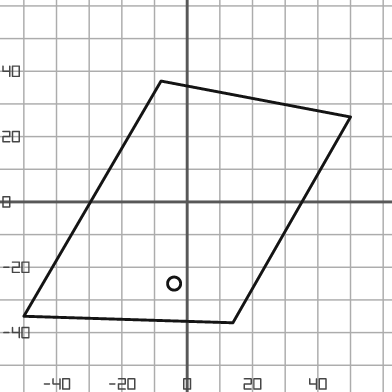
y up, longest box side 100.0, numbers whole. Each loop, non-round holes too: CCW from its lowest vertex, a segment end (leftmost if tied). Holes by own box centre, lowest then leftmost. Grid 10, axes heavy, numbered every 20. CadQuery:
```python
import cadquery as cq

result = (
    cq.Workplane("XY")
    .moveTo(14.0, -37.0)
    .lineTo(50.0, 26.0)
    .lineTo(-8.0, 37.0)
    .lineTo(-50.0, -35.0)
    .close()
    .moveTo(-4.0, -25.0)
    .circle(2.0)
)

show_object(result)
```